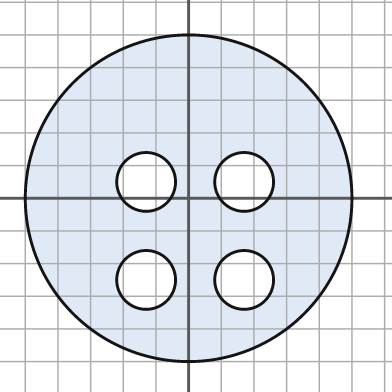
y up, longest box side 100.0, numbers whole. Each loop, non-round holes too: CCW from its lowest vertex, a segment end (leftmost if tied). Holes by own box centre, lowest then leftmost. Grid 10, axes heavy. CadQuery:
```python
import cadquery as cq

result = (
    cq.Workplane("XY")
    .moveTo(0.0, 0.0)
    .circle(50.0)
    .moveTo(-13.0, -25.0)
    .circle(9.0)
    .moveTo(17.0, -25.0)
    .circle(9.0)
    .moveTo(-13.0, 5.0)
    .circle(9.0)
    .moveTo(17.0, 5.0)
    .circle(9.0)
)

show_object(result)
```